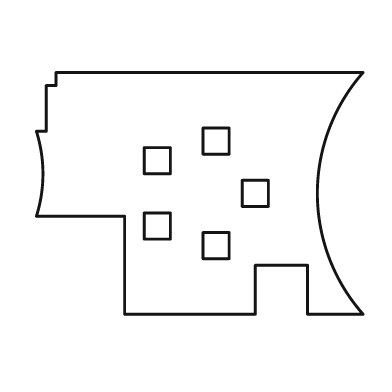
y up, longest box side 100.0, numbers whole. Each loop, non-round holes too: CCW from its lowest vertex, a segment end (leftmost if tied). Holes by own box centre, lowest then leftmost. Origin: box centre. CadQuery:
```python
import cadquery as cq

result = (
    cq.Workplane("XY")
    .moveTo(-23.0, -37.0)
    .lineTo(17.0, -37.0)
    .lineTo(17.0, -22.0)
    .lineTo(33.0, -22.0)
    .lineTo(33.0, -37.0)
    .lineTo(50.0, -37.0)
    .threePointArc((36.0, 0.0), (50.0, 37.0))
    .lineTo(-44.0, 37.0)
    .lineTo(-44.0, 33.0)
    .lineTo(-47.0, 33.0)
    .lineTo(-47.0, 19.0)
    .lineTo(-50.0, 19.0)
    .threePointArc((-48.0, 6.0), (-50.0, -7.0))
    .lineTo(-23.0, -7.0)
    .close()
    .moveTo(1.0, -20.0)
    .lineTo(9.0, -20.0)
    .lineTo(9.0, -12.0)
    .lineTo(1.0, -12.0)
    .close()
    .moveTo(-17.0, -14.0)
    .lineTo(-9.0, -14.0)
    .lineTo(-9.0, -6.0)
    .lineTo(-17.0, -6.0)
    .close()
    .moveTo(13.0, -4.0)
    .lineTo(21.0, -4.0)
    .lineTo(21.0, 4.0)
    .lineTo(13.0, 4.0)
    .close()
    .moveTo(-17.0, 6.0)
    .lineTo(-9.0, 6.0)
    .lineTo(-9.0, 14.0)
    .lineTo(-17.0, 14.0)
    .close()
    .moveTo(1.0, 12.0)
    .lineTo(9.0, 12.0)
    .lineTo(9.0, 20.0)
    .lineTo(1.0, 20.0)
    .close()
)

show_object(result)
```